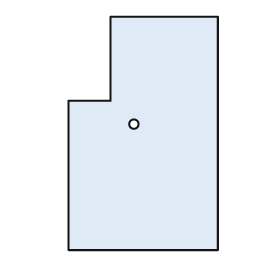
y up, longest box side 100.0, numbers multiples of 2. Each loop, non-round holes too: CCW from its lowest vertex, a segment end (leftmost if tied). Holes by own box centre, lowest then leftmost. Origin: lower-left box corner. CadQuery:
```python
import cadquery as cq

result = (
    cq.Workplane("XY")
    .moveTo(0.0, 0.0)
    .lineTo(64.0, 0.0)
    .lineTo(64.0, 100.0)
    .lineTo(18.0, 100.0)
    .lineTo(18.0, 64.0)
    .lineTo(0.0, 64.0)
    .close()
    .moveTo(28.0, 54.0)
    .circle(2.0)
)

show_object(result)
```